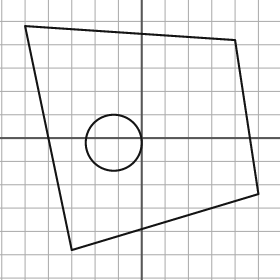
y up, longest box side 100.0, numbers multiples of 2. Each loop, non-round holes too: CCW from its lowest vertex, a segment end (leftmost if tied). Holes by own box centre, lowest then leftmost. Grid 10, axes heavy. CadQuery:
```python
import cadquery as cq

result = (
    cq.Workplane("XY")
    .moveTo(-30.0, -48.0)
    .lineTo(50.0, -24.0)
    .lineTo(40.0, 42.0)
    .lineTo(-50.0, 48.0)
    .close()
    .moveTo(-12.0, -2.0)
    .circle(12.0)
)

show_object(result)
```